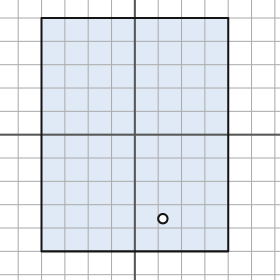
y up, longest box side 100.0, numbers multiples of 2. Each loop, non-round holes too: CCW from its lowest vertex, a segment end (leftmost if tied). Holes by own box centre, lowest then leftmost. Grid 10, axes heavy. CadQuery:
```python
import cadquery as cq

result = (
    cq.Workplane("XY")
    .moveTo(-40.0, -50.0)
    .lineTo(40.0, -50.0)
    .lineTo(40.0, 50.0)
    .lineTo(-40.0, 50.0)
    .close()
    .moveTo(12.0, -36.0)
    .circle(2.0)
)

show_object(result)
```